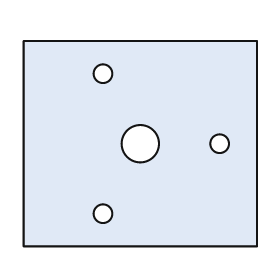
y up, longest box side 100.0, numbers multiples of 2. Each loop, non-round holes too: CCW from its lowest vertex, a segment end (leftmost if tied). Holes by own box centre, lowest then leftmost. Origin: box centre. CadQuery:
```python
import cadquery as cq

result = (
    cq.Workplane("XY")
    .moveTo(-50.0, -44.0)
    .lineTo(50.0, -44.0)
    .lineTo(50.0, 44.0)
    .lineTo(-50.0, 44.0)
    .close()
    .moveTo(-16.0, -30.0)
    .circle(4.0)
    .moveTo(0.0, 0.0)
    .circle(8.0)
    .moveTo(34.0, 0.0)
    .circle(4.0)
    .moveTo(-16.0, 30.0)
    .circle(4.0)
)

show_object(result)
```